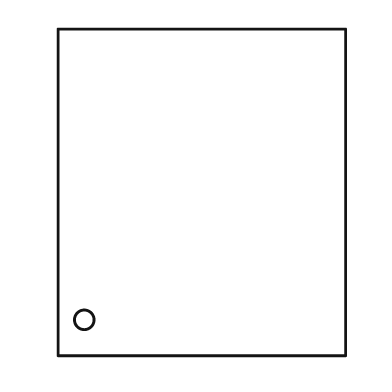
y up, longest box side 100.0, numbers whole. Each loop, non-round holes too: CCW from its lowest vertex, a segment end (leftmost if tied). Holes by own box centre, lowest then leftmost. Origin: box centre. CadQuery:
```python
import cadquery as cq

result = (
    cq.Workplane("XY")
    .moveTo(-44.0, -50.0)
    .lineTo(44.0, -50.0)
    .lineTo(44.0, 50.0)
    .lineTo(-44.0, 50.0)
    .close()
    .moveTo(-36.0, -39.0)
    .circle(3.0)
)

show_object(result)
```